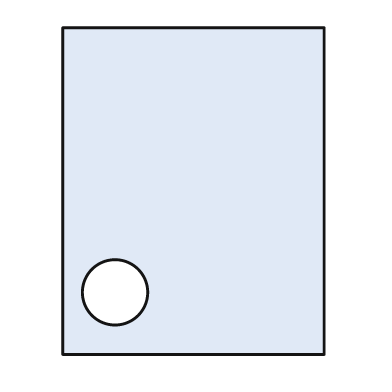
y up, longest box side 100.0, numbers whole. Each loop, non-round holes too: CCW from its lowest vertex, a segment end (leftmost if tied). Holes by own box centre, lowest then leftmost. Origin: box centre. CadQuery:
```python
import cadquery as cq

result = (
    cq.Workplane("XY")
    .moveTo(-40.0, -50.0)
    .lineTo(40.0, -50.0)
    .lineTo(40.0, 50.0)
    .lineTo(-40.0, 50.0)
    .close()
    .moveTo(-24.0, -31.0)
    .circle(10.0)
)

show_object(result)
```